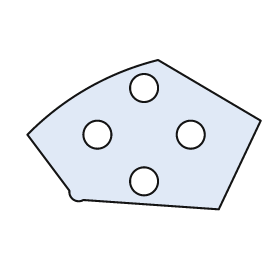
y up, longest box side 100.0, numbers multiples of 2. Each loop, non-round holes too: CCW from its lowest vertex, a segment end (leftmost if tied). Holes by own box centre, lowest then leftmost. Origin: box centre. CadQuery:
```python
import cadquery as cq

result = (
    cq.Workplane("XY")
    .moveTo(32.0, -32.0)
    .lineTo(50.0, 6.0)
    .lineTo(6.0, 32.0)
    .threePointArc((-24.0, 20.0), (-50.0, 0.0))
    .lineTo(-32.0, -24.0)
    .threePointArc((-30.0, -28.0), (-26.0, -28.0))
    .close()
    .moveTo(0.0, -20.0)
    .circle(6.0)
    .moveTo(-20.0, 0.0)
    .circle(6.0)
    .moveTo(20.0, 0.0)
    .circle(6.0)
    .moveTo(0.0, 20.0)
    .circle(6.0)
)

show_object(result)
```